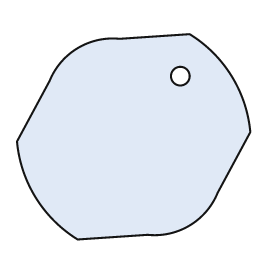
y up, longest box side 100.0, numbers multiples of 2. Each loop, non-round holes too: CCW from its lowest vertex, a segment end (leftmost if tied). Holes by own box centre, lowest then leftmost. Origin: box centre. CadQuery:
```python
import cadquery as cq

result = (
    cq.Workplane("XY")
    .moveTo(-24.0, -44.0)
    .lineTo(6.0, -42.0)
    .threePointArc((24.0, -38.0), (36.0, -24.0))
    .lineTo(50.0, 2.0)
    .threePointArc((42.0, 26.0), (24.0, 44.0))
    .lineTo(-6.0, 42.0)
    .threePointArc((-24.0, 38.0), (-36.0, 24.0))
    .lineTo(-50.0, -2.0)
    .threePointArc((-42.0, -26.0), (-24.0, -44.0))
    .close()
    .moveTo(20.0, 26.0)
    .circle(4.0)
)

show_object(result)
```